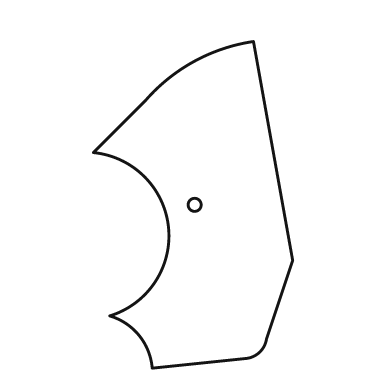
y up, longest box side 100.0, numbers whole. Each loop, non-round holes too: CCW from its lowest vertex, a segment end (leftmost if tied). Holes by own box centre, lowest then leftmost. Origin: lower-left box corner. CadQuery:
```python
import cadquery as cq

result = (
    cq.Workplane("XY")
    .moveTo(18.0, 0.0)
    .lineTo(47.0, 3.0)
    .threePointArc((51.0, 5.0), (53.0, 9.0))
    .lineTo(61.0, 33.0)
    .lineTo(49.0, 100.0)
    .threePointArc((31.0, 94.0), (16.0, 82.0))
    .lineTo(0.0, 66.0)
    .threePointArc((23.0, 43.0), (5.0, 16.0))
    .threePointArc((14.0, 10.0), (18.0, 0.0))
    .close()
    .moveTo(31.0, 50.0)
    .circle(2.0)
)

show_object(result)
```